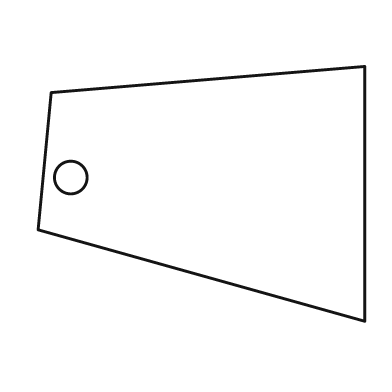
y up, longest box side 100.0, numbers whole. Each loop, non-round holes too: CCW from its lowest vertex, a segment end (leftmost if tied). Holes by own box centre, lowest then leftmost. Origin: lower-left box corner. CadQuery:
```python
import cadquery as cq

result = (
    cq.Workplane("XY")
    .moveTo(100.0, 0.0)
    .lineTo(100.0, 78.0)
    .lineTo(4.0, 70.0)
    .lineTo(0.0, 28.0)
    .close()
    .moveTo(10.0, 44.0)
    .circle(5.0)
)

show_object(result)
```